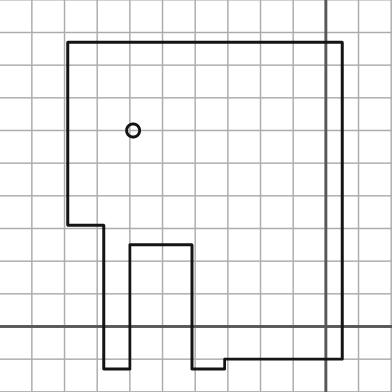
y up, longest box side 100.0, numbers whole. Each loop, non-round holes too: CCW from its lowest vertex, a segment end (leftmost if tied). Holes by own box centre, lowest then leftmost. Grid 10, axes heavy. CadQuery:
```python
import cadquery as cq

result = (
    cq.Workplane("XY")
    .moveTo(-68.0, -13.0)
    .lineTo(-60.0, -13.0)
    .lineTo(-60.0, 25.0)
    .lineTo(-41.0, 25.0)
    .lineTo(-41.0, -13.0)
    .lineTo(-31.0, -13.0)
    .lineTo(-31.0, -10.0)
    .lineTo(5.0, -10.0)
    .lineTo(5.0, 87.0)
    .lineTo(-79.0, 87.0)
    .lineTo(-79.0, 31.0)
    .lineTo(-68.0, 31.0)
    .close()
    .moveTo(-59.0, 60.0)
    .circle(2.0)
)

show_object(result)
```